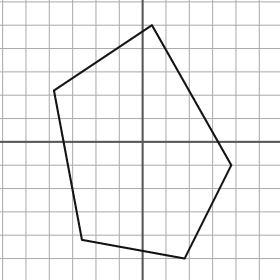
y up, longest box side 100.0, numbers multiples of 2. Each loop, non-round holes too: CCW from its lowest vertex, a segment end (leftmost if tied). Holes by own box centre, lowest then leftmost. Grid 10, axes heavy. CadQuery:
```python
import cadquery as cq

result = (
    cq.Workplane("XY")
    .moveTo(18.0, -50.0)
    .lineTo(38.0, -10.0)
    .lineTo(4.0, 50.0)
    .lineTo(-38.0, 22.0)
    .lineTo(-26.0, -42.0)
    .close()
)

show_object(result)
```